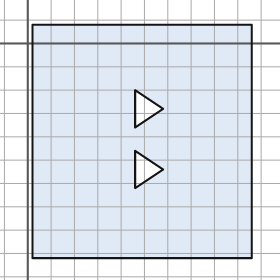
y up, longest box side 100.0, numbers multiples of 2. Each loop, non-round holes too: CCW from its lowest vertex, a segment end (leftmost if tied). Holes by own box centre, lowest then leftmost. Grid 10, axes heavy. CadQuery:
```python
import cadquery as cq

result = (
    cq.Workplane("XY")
    .moveTo(2.0, -92.0)
    .lineTo(96.0, -92.0)
    .lineTo(96.0, 8.0)
    .lineTo(2.0, 8.0)
    .close()
    .moveTo(46.0, -62.0)
    .lineTo(58.0, -54.0)
    .lineTo(46.0, -46.0)
    .close()
    .moveTo(46.0, -36.0)
    .lineTo(58.0, -28.0)
    .lineTo(46.0, -20.0)
    .close()
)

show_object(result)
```